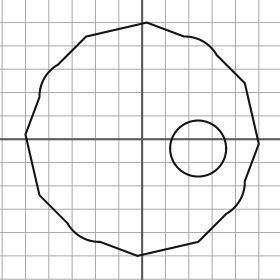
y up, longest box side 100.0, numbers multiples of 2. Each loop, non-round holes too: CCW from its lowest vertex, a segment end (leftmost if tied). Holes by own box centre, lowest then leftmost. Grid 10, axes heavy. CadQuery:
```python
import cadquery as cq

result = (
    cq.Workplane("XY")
    .moveTo(-2.0, -50.0)
    .lineTo(24.0, -44.0)
    .lineTo(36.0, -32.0)
    .threePointArc((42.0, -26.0), (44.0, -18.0))
    .lineTo(50.0, -2.0)
    .lineTo(44.0, 24.0)
    .lineTo(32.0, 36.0)
    .threePointArc((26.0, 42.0), (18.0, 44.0))
    .lineTo(2.0, 50.0)
    .lineTo(-24.0, 44.0)
    .lineTo(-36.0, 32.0)
    .threePointArc((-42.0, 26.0), (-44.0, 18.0))
    .lineTo(-50.0, 2.0)
    .lineTo(-44.0, -24.0)
    .lineTo(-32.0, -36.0)
    .threePointArc((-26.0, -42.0), (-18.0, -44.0))
    .close()
    .moveTo(24.0, -4.0)
    .circle(12.0)
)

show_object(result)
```